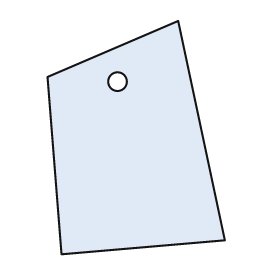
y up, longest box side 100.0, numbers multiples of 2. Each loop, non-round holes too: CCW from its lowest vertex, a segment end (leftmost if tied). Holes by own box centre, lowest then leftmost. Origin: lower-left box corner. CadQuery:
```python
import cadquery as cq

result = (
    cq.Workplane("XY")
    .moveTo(6.0, 0.0)
    .lineTo(76.0, 6.0)
    .lineTo(56.0, 100.0)
    .lineTo(0.0, 76.0)
    .close()
    .moveTo(30.0, 74.0)
    .circle(4.0)
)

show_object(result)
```